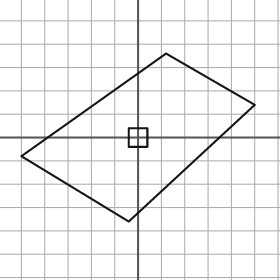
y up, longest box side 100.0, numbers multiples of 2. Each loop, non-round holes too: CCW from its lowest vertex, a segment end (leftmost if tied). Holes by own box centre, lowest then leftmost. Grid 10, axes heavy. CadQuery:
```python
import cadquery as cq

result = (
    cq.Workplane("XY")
    .moveTo(-4.0, -36.0)
    .lineTo(50.0, 14.0)
    .lineTo(12.0, 36.0)
    .lineTo(-50.0, -8.0)
    .close()
    .moveTo(-4.0, -4.0)
    .lineTo(4.0, -4.0)
    .lineTo(4.0, 4.0)
    .lineTo(-4.0, 4.0)
    .close()
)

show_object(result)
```